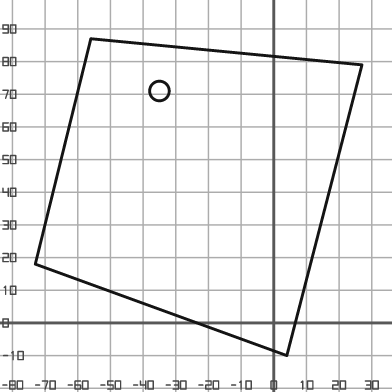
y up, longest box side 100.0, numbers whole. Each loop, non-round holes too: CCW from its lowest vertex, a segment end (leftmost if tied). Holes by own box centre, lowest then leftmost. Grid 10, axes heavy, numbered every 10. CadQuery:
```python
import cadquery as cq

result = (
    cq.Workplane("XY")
    .moveTo(4.0, -10.0)
    .lineTo(27.0, 79.0)
    .lineTo(-56.0, 87.0)
    .lineTo(-73.0, 18.0)
    .close()
    .moveTo(-35.0, 71.0)
    .circle(3.0)
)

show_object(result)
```